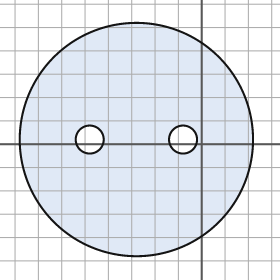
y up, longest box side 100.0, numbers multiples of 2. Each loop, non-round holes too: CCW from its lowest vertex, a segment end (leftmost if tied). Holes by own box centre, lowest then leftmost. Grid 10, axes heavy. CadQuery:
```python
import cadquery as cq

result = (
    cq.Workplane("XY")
    .moveTo(-28.0, 2.0)
    .circle(50.0)
    .moveTo(-48.0, 2.0)
    .circle(6.0)
    .moveTo(-8.0, 2.0)
    .circle(6.0)
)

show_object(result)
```